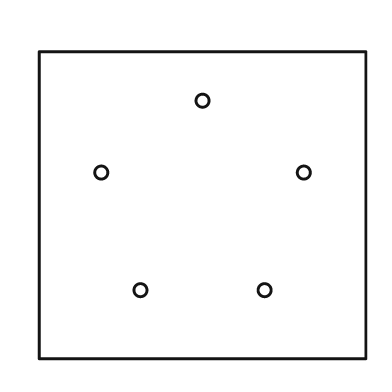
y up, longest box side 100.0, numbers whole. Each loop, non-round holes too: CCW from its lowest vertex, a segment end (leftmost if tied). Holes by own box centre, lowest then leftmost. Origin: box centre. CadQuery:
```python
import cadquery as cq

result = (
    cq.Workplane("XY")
    .moveTo(-50.0, -47.0)
    .lineTo(50.0, -47.0)
    .lineTo(50.0, 47.0)
    .lineTo(-50.0, 47.0)
    .close()
    .moveTo(-19.0, -26.0)
    .circle(2.0)
    .moveTo(19.0, -26.0)
    .circle(2.0)
    .moveTo(-31.0, 10.0)
    .circle(2.0)
    .moveTo(31.0, 10.0)
    .circle(2.0)
    .moveTo(0.0, 32.0)
    .circle(2.0)
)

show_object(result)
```